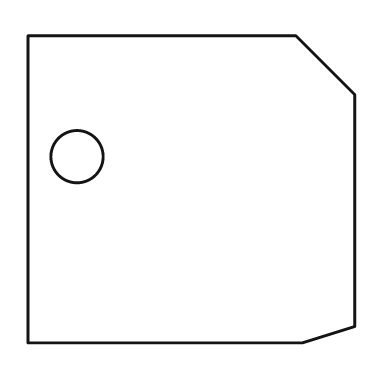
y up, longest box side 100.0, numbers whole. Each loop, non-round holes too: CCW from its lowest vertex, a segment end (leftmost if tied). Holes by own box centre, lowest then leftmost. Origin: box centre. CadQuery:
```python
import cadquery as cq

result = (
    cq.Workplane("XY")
    .moveTo(-50.0, -47.0)
    .lineTo(34.0, -47.0)
    .lineTo(50.0, -42.0)
    .lineTo(50.0, 29.0)
    .lineTo(32.0, 47.0)
    .lineTo(-50.0, 47.0)
    .close()
    .moveTo(-35.0, 10.0)
    .circle(8.0)
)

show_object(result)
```